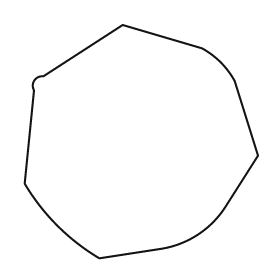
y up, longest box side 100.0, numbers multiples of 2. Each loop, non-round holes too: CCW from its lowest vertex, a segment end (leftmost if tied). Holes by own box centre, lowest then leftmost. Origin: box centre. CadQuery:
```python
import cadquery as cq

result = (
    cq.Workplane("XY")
    .moveTo(-18.0, -50.0)
    .lineTo(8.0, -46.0)
    .threePointArc((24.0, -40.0), (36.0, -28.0))
    .lineTo(50.0, -6.0)
    .lineTo(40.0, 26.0)
    .threePointArc((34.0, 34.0), (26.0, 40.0))
    .lineTo(-8.0, 50.0)
    .lineTo(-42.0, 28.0)
    .threePointArc((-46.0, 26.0), (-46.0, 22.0))
    .lineTo(-50.0, -18.0)
    .threePointArc((-36.0, -36.0), (-18.0, -50.0))
    .close()
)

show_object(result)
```